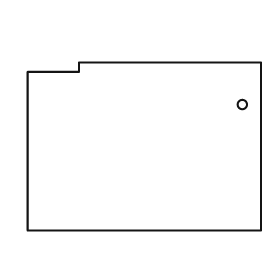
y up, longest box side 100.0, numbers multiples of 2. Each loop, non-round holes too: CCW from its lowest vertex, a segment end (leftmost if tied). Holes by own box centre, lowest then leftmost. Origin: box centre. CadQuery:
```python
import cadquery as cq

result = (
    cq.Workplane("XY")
    .moveTo(-50.0, -36.0)
    .lineTo(50.0, -36.0)
    .lineTo(50.0, 36.0)
    .lineTo(-28.0, 36.0)
    .lineTo(-28.0, 32.0)
    .lineTo(-50.0, 32.0)
    .close()
    .moveTo(42.0, 18.0)
    .circle(2.0)
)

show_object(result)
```